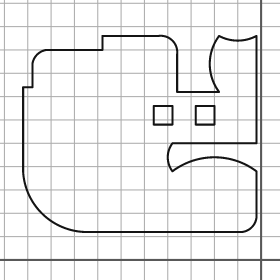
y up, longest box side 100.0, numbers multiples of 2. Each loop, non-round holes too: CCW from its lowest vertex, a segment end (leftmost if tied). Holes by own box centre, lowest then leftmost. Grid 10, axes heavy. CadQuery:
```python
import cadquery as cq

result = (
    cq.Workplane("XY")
    .moveTo(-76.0, 12.0)
    .lineTo(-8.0, 12.0)
    .threePointArc((-4.0, 14.0), (-2.0, 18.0))
    .lineTo(-2.0, 38.0)
    .threePointArc((-20.0, 44.0), (-38.0, 38.0))
    .threePointArc((-40.0, 44.0), (-38.0, 50.0))
    .lineTo(-2.0, 50.0)
    .lineTo(-2.0, 96.0)
    .threePointArc((-10.0, 94.0), (-18.0, 96.0))
    .threePointArc((-22.0, 84.0), (-18.0, 72.0))
    .lineTo(-36.0, 72.0)
    .lineTo(-36.0, 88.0)
    .threePointArc((-38.0, 94.0), (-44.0, 96.0))
    .lineTo(-68.0, 96.0)
    .lineTo(-68.0, 90.0)
    .lineTo(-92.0, 90.0)
    .threePointArc((-96.0, 88.0), (-98.0, 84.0))
    .lineTo(-98.0, 74.0)
    .lineTo(-102.0, 74.0)
    .lineTo(-102.0, 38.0)
    .threePointArc((-94.0, 20.0), (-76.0, 12.0))
    .close()
    .moveTo(-46.0, 58.0)
    .lineTo(-38.0, 58.0)
    .lineTo(-38.0, 66.0)
    .lineTo(-46.0, 66.0)
    .close()
    .moveTo(-28.0, 58.0)
    .lineTo(-20.0, 58.0)
    .lineTo(-20.0, 66.0)
    .lineTo(-28.0, 66.0)
    .close()
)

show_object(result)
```